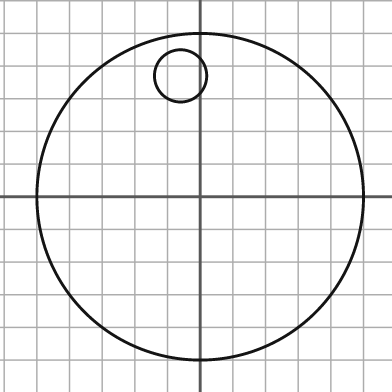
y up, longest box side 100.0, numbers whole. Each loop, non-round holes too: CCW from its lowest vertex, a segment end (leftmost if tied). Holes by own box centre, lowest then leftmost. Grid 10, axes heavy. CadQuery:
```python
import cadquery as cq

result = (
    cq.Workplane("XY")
    .moveTo(0.0, 0.0)
    .circle(50.0)
    .moveTo(-6.0, 37.0)
    .circle(8.0)
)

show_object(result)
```